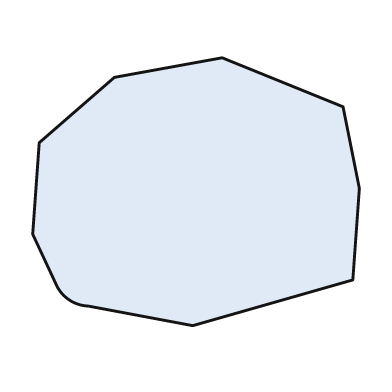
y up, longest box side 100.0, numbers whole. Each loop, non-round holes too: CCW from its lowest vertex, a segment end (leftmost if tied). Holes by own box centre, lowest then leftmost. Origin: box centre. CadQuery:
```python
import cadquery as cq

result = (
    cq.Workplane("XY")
    .moveTo(-1.0, -41.0)
    .lineTo(48.0, -27.0)
    .lineTo(50.0, 1.0)
    .lineTo(45.0, 26.0)
    .lineTo(8.0, 41.0)
    .lineTo(-25.0, 35.0)
    .lineTo(-48.0, 15.0)
    .lineTo(-50.0, -13.0)
    .lineTo(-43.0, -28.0)
    .threePointArc((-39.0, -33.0), (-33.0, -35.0))
    .close()
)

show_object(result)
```